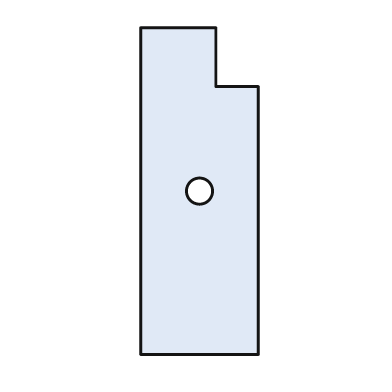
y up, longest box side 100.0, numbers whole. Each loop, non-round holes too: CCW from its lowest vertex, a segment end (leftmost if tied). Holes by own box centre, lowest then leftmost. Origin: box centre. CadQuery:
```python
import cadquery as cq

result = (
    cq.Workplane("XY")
    .moveTo(-18.0, -50.0)
    .lineTo(18.0, -50.0)
    .lineTo(18.0, 32.0)
    .lineTo(5.0, 32.0)
    .lineTo(5.0, 50.0)
    .lineTo(-18.0, 50.0)
    .close()
    .moveTo(0.0, 0.0)
    .circle(4.0)
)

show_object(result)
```